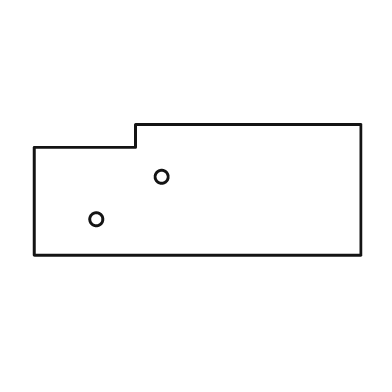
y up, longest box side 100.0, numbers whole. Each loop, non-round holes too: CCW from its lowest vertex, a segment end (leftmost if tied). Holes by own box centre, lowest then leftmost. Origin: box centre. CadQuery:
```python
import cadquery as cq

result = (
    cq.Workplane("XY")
    .moveTo(-50.0, -20.0)
    .lineTo(50.0, -20.0)
    .lineTo(50.0, 20.0)
    .lineTo(-19.0, 20.0)
    .lineTo(-19.0, 13.0)
    .lineTo(-50.0, 13.0)
    .close()
    .moveTo(-31.0, -9.0)
    .circle(2.0)
    .moveTo(-11.0, 4.0)
    .circle(2.0)
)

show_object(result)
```